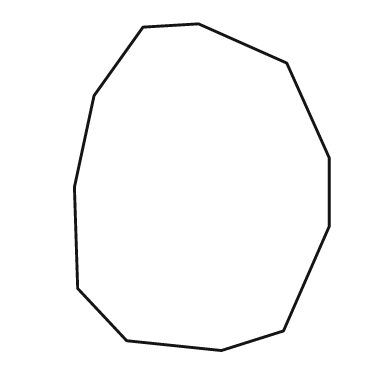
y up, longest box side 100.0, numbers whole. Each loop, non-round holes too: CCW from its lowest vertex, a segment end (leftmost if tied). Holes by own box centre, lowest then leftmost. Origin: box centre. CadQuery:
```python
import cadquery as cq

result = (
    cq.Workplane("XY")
    .moveTo(6.0, -50.0)
    .lineTo(25.0, -44.0)
    .lineTo(39.0, -12.0)
    .lineTo(39.0, 9.0)
    .lineTo(26.0, 38.0)
    .lineTo(-1.0, 50.0)
    .lineTo(-18.0, 49.0)
    .lineTo(-33.0, 28.0)
    .lineTo(-39.0, 0.0)
    .lineTo(-38.0, -31.0)
    .lineTo(-23.0, -47.0)
    .close()
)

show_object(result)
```